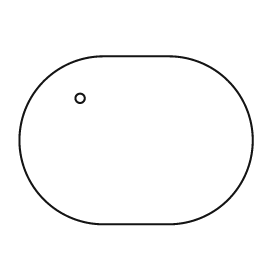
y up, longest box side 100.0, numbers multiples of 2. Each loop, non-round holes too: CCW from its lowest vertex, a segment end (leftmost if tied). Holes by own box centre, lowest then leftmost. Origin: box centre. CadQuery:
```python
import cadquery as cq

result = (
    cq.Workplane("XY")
    .moveTo(-14.0, -36.0)
    .lineTo(14.0, -36.0)
    .threePointArc((50.0, 0.0), (14.0, 36.0))
    .lineTo(-14.0, 36.0)
    .threePointArc((-50.0, 0.0), (-14.0, -36.0))
    .close()
    .moveTo(-24.0, 18.0)
    .circle(2.0)
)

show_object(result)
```